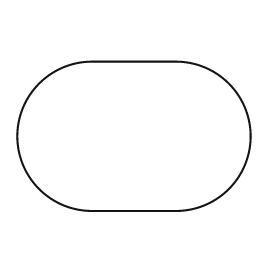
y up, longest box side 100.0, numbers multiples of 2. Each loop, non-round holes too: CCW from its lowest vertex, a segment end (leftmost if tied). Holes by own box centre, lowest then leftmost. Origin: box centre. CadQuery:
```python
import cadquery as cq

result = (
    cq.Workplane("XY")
    .moveTo(-18.0, -32.0)
    .lineTo(18.0, -32.0)
    .threePointArc((50.0, 0.0), (18.0, 32.0))
    .lineTo(-18.0, 32.0)
    .threePointArc((-50.0, 0.0), (-18.0, -32.0))
    .close()
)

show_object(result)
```